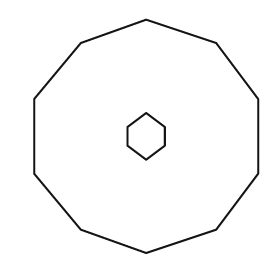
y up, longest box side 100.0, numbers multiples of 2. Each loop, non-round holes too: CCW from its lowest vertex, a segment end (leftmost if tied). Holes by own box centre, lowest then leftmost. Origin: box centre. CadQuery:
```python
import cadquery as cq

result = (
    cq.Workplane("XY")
    .moveTo(0.0, -50.0)
    .lineTo(30.0, -40.0)
    .lineTo(48.0, -16.0)
    .lineTo(48.0, 16.0)
    .lineTo(30.0, 40.0)
    .lineTo(0.0, 50.0)
    .lineTo(-28.0, 40.0)
    .lineTo(-48.0, 16.0)
    .lineTo(-48.0, -16.0)
    .lineTo(-28.0, -40.0)
    .close()
    .moveTo(0.0, -10.0)
    .lineTo(8.0, -4.0)
    .lineTo(8.0, 4.0)
    .lineTo(0.0, 10.0)
    .lineTo(-8.0, 4.0)
    .lineTo(-8.0, -4.0)
    .close()
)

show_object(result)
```